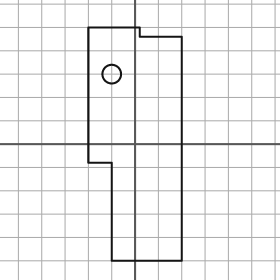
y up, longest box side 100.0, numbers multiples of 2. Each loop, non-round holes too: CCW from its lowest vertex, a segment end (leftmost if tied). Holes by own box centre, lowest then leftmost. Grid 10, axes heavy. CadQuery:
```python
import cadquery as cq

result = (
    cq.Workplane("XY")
    .moveTo(-10.0, -50.0)
    .lineTo(20.0, -50.0)
    .lineTo(20.0, 46.0)
    .lineTo(2.0, 46.0)
    .lineTo(2.0, 50.0)
    .lineTo(-20.0, 50.0)
    .lineTo(-20.0, -8.0)
    .lineTo(-10.0, -8.0)
    .close()
    .moveTo(-10.0, 30.0)
    .circle(4.0)
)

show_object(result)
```